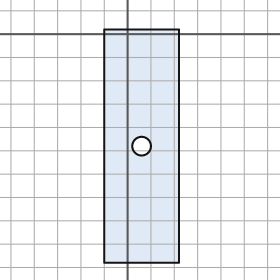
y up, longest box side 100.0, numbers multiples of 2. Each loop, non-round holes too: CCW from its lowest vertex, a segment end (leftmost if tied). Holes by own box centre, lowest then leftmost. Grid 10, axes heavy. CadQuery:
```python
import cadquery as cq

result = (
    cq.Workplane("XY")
    .moveTo(-10.0, -98.0)
    .lineTo(22.0, -98.0)
    .lineTo(22.0, 2.0)
    .lineTo(-10.0, 2.0)
    .close()
    .moveTo(6.0, -48.0)
    .circle(4.0)
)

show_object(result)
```